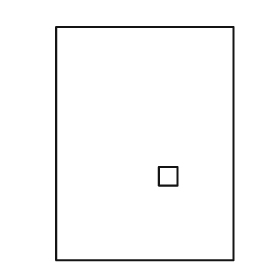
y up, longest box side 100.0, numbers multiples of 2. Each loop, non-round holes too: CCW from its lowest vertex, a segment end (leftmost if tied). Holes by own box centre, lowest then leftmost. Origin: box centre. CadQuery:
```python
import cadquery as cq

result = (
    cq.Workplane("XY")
    .moveTo(-38.0, -50.0)
    .lineTo(38.0, -50.0)
    .lineTo(38.0, 50.0)
    .lineTo(-38.0, 50.0)
    .close()
    .moveTo(6.0, -18.0)
    .lineTo(14.0, -18.0)
    .lineTo(14.0, -10.0)
    .lineTo(6.0, -10.0)
    .close()
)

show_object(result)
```